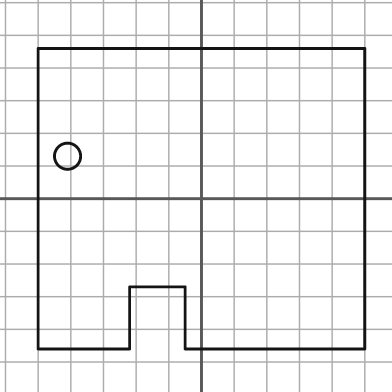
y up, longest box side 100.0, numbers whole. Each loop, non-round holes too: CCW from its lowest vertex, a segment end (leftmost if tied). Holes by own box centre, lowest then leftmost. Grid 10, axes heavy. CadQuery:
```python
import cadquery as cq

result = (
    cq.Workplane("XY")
    .moveTo(-50.0, -46.0)
    .lineTo(-22.0, -46.0)
    .lineTo(-22.0, -27.0)
    .lineTo(-5.0, -27.0)
    .lineTo(-5.0, -46.0)
    .lineTo(50.0, -46.0)
    .lineTo(50.0, 46.0)
    .lineTo(-50.0, 46.0)
    .close()
    .moveTo(-41.0, 13.0)
    .circle(4.0)
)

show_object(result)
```